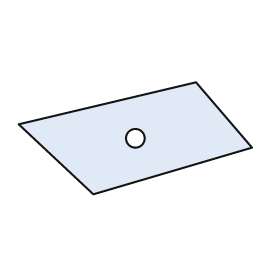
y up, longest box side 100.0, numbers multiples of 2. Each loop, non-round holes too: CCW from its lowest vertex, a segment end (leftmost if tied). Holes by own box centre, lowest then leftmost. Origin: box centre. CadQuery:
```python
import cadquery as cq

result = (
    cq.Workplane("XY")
    .moveTo(-18.0, -24.0)
    .lineTo(50.0, -4.0)
    .lineTo(26.0, 24.0)
    .lineTo(-50.0, 6.0)
    .close()
    .moveTo(0.0, 0.0)
    .circle(4.0)
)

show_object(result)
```